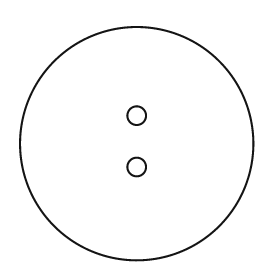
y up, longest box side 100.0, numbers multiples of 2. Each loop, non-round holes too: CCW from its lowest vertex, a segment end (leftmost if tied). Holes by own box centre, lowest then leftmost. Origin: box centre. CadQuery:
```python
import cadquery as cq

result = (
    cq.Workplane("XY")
    .moveTo(0.0, 0.0)
    .circle(50.0)
    .moveTo(0.0, -10.0)
    .circle(4.0)
    .moveTo(0.0, 12.0)
    .circle(4.0)
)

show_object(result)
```